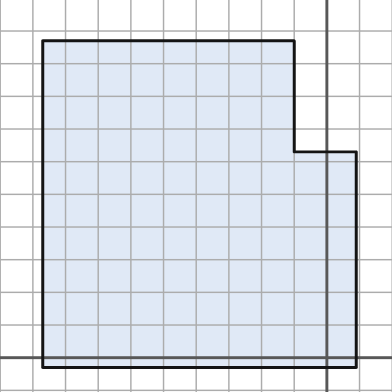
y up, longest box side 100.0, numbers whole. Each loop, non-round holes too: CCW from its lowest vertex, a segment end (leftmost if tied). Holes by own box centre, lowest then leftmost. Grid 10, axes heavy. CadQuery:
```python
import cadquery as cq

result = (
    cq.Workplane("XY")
    .moveTo(-87.0, -3.0)
    .lineTo(9.0, -3.0)
    .lineTo(9.0, 63.0)
    .lineTo(-10.0, 63.0)
    .lineTo(-10.0, 97.0)
    .lineTo(-87.0, 97.0)
    .close()
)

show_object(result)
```